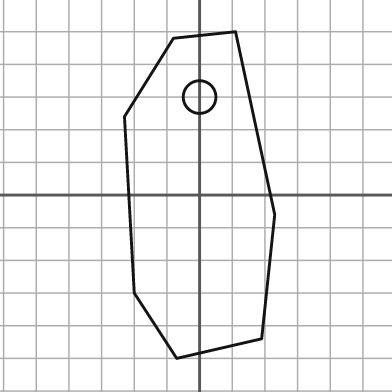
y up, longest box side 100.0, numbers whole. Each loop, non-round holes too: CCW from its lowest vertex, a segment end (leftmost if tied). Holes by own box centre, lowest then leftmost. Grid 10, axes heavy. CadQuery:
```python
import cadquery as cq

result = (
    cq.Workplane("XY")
    .moveTo(-7.0, -50.0)
    .lineTo(19.0, -44.0)
    .lineTo(23.0, -6.0)
    .lineTo(11.0, 50.0)
    .lineTo(-8.0, 48.0)
    .lineTo(-23.0, 24.0)
    .lineTo(-20.0, -30.0)
    .close()
    .moveTo(0.0, 30.0)
    .circle(5.0)
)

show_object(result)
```